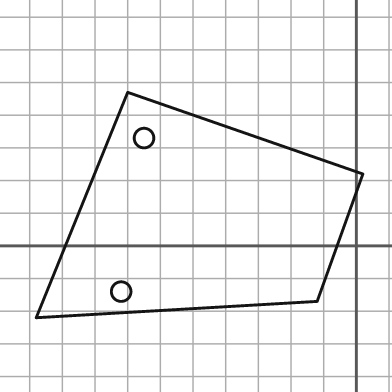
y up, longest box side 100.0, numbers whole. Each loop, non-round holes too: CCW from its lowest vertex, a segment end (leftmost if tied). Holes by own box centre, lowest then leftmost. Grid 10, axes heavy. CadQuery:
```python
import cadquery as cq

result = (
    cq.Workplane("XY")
    .moveTo(-98.0, -22.0)
    .lineTo(-12.0, -17.0)
    .lineTo(2.0, 22.0)
    .lineTo(-70.0, 47.0)
    .close()
    .moveTo(-72.0, -14.0)
    .circle(3.0)
    .moveTo(-65.0, 33.0)
    .circle(3.0)
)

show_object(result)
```